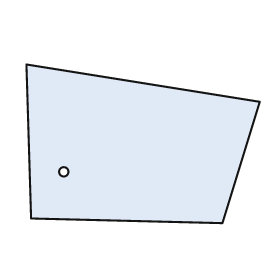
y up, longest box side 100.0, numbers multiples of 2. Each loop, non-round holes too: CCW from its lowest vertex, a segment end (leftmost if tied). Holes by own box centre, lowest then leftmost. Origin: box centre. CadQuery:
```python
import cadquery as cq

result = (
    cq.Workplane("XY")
    .moveTo(34.0, -34.0)
    .lineTo(50.0, 18.0)
    .lineTo(-50.0, 34.0)
    .lineTo(-48.0, -32.0)
    .close()
    .moveTo(-34.0, -12.0)
    .circle(2.0)
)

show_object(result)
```